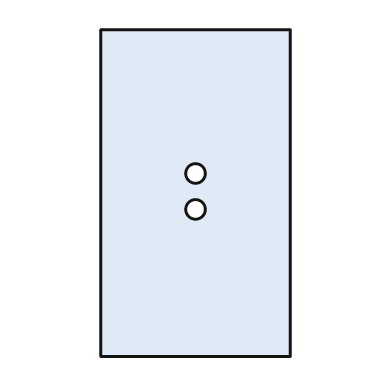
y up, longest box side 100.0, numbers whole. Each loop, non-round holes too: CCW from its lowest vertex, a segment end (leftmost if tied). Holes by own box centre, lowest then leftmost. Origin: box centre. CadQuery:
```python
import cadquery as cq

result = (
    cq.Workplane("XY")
    .moveTo(-29.0, -50.0)
    .lineTo(29.0, -50.0)
    .lineTo(29.0, 50.0)
    .lineTo(-29.0, 50.0)
    .close()
    .moveTo(0.0, -5.0)
    .circle(3.0)
    .moveTo(0.0, 6.0)
    .circle(3.0)
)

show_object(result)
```